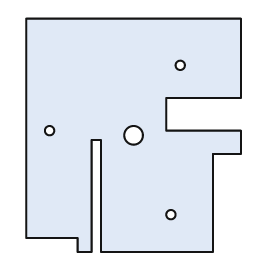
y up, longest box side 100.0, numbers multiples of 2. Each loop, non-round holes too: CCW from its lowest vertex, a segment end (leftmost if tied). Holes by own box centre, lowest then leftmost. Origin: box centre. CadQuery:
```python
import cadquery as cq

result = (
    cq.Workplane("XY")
    .moveTo(-24.0, -50.0)
    .lineTo(-18.0, -50.0)
    .lineTo(-18.0, -2.0)
    .lineTo(-14.0, -2.0)
    .lineTo(-14.0, -50.0)
    .lineTo(34.0, -50.0)
    .lineTo(34.0, -8.0)
    .lineTo(46.0, -8.0)
    .lineTo(46.0, 2.0)
    .lineTo(14.0, 2.0)
    .lineTo(14.0, 16.0)
    .lineTo(46.0, 16.0)
    .lineTo(46.0, 50.0)
    .lineTo(-46.0, 50.0)
    .lineTo(-46.0, -44.0)
    .lineTo(-24.0, -44.0)
    .close()
    .moveTo(16.0, -34.0)
    .circle(2.0)
    .moveTo(0.0, 0.0)
    .circle(4.0)
    .moveTo(-36.0, 2.0)
    .circle(2.0)
    .moveTo(20.0, 30.0)
    .circle(2.0)
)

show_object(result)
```